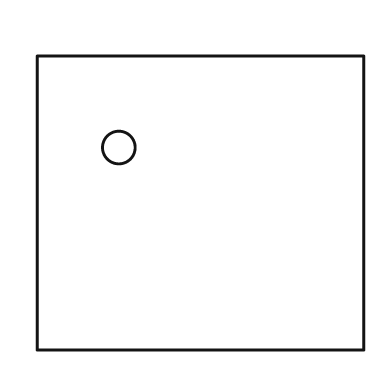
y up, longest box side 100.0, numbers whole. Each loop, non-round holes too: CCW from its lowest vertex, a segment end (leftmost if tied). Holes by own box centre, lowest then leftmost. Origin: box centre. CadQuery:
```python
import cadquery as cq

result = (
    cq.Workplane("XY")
    .moveTo(-50.0, -45.0)
    .lineTo(50.0, -45.0)
    .lineTo(50.0, 45.0)
    .lineTo(-50.0, 45.0)
    .close()
    .moveTo(-25.0, 17.0)
    .circle(5.0)
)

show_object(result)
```